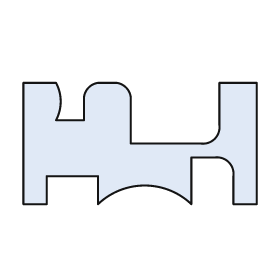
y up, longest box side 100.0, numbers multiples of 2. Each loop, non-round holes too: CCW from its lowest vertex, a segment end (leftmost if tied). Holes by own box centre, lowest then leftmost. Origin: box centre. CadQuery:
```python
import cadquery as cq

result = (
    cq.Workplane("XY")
    .moveTo(-50.0, -26.0)
    .lineTo(-40.0, -26.0)
    .lineTo(-40.0, -14.0)
    .lineTo(-18.0, -14.0)
    .lineTo(-18.0, -26.0)
    .threePointArc((2.0, -18.0), (22.0, -26.0))
    .lineTo(22.0, -6.0)
    .lineTo(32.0, -6.0)
    .threePointArc((38.0, -8.0), (40.0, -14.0))
    .lineTo(40.0, -26.0)
    .lineTo(50.0, -26.0)
    .lineTo(50.0, 26.0)
    .lineTo(34.0, 26.0)
    .lineTo(34.0, 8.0)
    .threePointArc((32.0, 2.0), (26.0, 0.0))
    .lineTo(-4.0, 0.0)
    .lineTo(-4.0, 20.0)
    .threePointArc((-6.0, 24.0), (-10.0, 26.0))
    .lineTo(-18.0, 26.0)
    .threePointArc((-22.0, 24.0), (-24.0, 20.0))
    .lineTo(-24.0, 10.0)
    .lineTo(-36.0, 10.0)
    .threePointArc((-34.0, 18.0), (-36.0, 26.0))
    .lineTo(-50.0, 26.0)
    .close()
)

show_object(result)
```